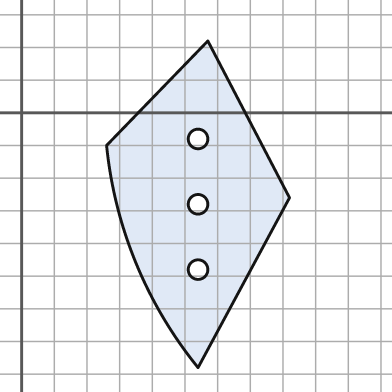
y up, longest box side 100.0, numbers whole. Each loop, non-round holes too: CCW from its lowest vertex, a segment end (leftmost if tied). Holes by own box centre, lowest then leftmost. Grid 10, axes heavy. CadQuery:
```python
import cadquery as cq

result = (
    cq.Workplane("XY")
    .moveTo(54.0, -78.0)
    .lineTo(82.0, -26.0)
    .lineTo(57.0, 22.0)
    .lineTo(26.0, -10.0)
    .threePointArc((35.0, -46.0), (54.0, -78.0))
    .close()
    .moveTo(54.0, -48.0)
    .circle(3.0)
    .moveTo(54.0, -28.0)
    .circle(3.0)
    .moveTo(54.0, -8.0)
    .circle(3.0)
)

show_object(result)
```